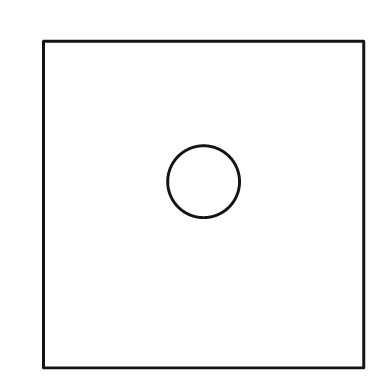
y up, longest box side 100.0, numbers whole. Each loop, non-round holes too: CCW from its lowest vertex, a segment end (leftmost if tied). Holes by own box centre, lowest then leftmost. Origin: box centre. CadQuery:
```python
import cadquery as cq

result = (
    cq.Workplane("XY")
    .moveTo(-49.0, -50.0)
    .lineTo(49.0, -50.0)
    .lineTo(49.0, 50.0)
    .lineTo(-49.0, 50.0)
    .close()
    .moveTo(0.0, 7.0)
    .circle(11.0)
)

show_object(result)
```